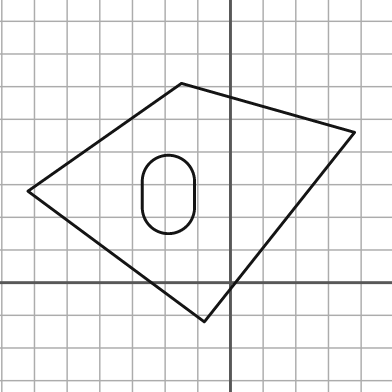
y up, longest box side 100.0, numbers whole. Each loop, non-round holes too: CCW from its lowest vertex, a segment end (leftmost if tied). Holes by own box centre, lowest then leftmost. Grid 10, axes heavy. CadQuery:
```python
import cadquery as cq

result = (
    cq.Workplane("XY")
    .moveTo(-8.0, -12.0)
    .lineTo(38.0, 46.0)
    .lineTo(-15.0, 61.0)
    .lineTo(-62.0, 28.0)
    .close()
    .moveTo(-27.0, 23.0)
    .threePointArc((-19.0, 15.0), (-11.0, 23.0))
    .lineTo(-11.0, 31.0)
    .threePointArc((-19.0, 39.0), (-27.0, 31.0))
    .close()
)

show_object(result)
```